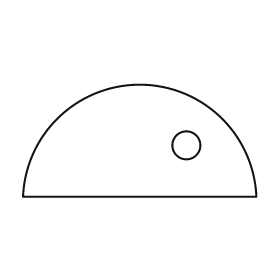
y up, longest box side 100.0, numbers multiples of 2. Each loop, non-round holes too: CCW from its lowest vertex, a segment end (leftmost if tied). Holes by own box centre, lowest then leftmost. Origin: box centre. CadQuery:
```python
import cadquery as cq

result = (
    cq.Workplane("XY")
    .moveTo(-50.0, -24.0)
    .lineTo(50.0, -24.0)
    .threePointArc((0.0, 24.0), (-50.0, -24.0))
    .close()
    .moveTo(20.0, -2.0)
    .circle(6.0)
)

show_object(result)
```